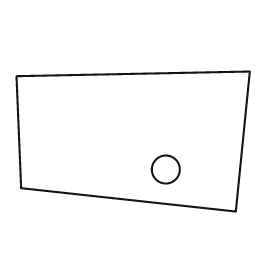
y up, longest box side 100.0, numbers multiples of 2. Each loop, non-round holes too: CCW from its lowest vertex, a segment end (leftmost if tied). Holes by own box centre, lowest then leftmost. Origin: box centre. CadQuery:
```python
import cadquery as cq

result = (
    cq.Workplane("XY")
    .moveTo(44.0, -30.0)
    .lineTo(50.0, 30.0)
    .lineTo(-50.0, 28.0)
    .lineTo(-48.0, -20.0)
    .close()
    .moveTo(14.0, -12.0)
    .circle(6.0)
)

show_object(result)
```